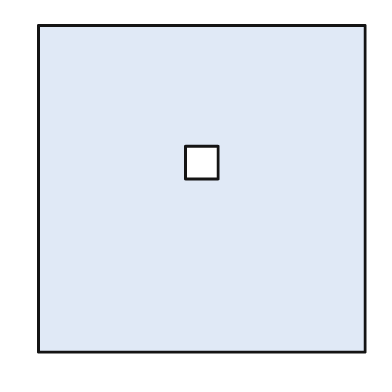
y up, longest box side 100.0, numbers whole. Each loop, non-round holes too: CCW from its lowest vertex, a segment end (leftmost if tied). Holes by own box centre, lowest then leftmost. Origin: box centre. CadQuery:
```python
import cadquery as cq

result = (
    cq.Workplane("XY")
    .moveTo(-50.0, -50.0)
    .lineTo(50.0, -50.0)
    .lineTo(50.0, 50.0)
    .lineTo(-50.0, 50.0)
    .close()
    .moveTo(-5.0, 3.0)
    .lineTo(5.0, 3.0)
    .lineTo(5.0, 13.0)
    .lineTo(-5.0, 13.0)
    .close()
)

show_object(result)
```